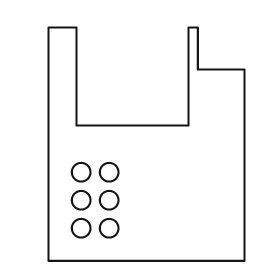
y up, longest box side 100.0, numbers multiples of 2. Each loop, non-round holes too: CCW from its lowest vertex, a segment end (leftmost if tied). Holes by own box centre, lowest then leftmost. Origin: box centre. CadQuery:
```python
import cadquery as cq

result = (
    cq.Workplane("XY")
    .moveTo(-42.0, -50.0)
    .lineTo(42.0, -50.0)
    .lineTo(42.0, 32.0)
    .lineTo(22.0, 32.0)
    .lineTo(22.0, 50.0)
    .lineTo(18.0, 50.0)
    .lineTo(18.0, 8.0)
    .lineTo(-30.0, 8.0)
    .lineTo(-30.0, 50.0)
    .lineTo(-42.0, 50.0)
    .close()
    .moveTo(-28.0, -36.0)
    .circle(4.0)
    .moveTo(-16.0, -36.0)
    .circle(4.0)
    .moveTo(-28.0, -24.0)
    .circle(4.0)
    .moveTo(-16.0, -24.0)
    .circle(4.0)
    .moveTo(-28.0, -12.0)
    .circle(4.0)
    .moveTo(-16.0, -12.0)
    .circle(4.0)
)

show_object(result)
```